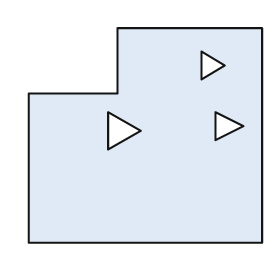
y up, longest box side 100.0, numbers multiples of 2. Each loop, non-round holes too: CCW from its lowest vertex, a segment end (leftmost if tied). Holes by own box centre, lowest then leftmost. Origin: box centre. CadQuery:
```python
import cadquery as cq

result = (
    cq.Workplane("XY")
    .moveTo(-50.0, -46.0)
    .lineTo(50.0, -46.0)
    .lineTo(50.0, 46.0)
    .lineTo(-12.0, 46.0)
    .lineTo(-12.0, 18.0)
    .lineTo(-50.0, 18.0)
    .close()
    .moveTo(-16.0, -6.0)
    .lineTo(-2.0, 2.0)
    .lineTo(-16.0, 10.0)
    .close()
    .moveTo(30.0, -2.0)
    .lineTo(42.0, 4.0)
    .lineTo(30.0, 10.0)
    .close()
    .moveTo(24.0, 24.0)
    .lineTo(34.0, 30.0)
    .lineTo(24.0, 36.0)
    .close()
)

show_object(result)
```